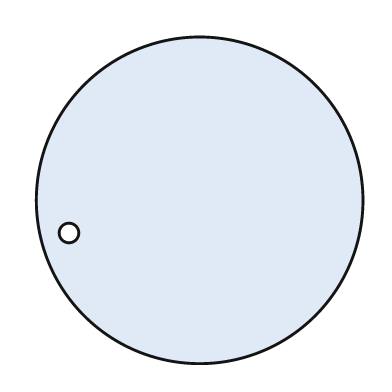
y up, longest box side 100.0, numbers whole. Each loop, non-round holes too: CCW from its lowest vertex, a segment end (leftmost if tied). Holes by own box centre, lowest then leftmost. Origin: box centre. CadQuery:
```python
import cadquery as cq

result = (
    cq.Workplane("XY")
    .moveTo(0.0, 0.0)
    .circle(50.0)
    .moveTo(-40.0, -10.0)
    .circle(3.0)
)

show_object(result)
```